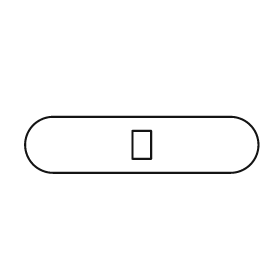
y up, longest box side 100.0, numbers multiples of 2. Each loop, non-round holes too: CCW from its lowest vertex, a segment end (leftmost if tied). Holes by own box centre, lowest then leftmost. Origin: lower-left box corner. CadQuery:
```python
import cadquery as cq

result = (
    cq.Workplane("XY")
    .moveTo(12.0, 0.0)
    .lineTo(88.0, 0.0)
    .threePointArc((100.0, 12.0), (88.0, 24.0))
    .lineTo(12.0, 24.0)
    .threePointArc((0.0, 12.0), (12.0, 0.0))
    .close()
    .moveTo(46.0, 6.0)
    .lineTo(54.0, 6.0)
    .lineTo(54.0, 18.0)
    .lineTo(46.0, 18.0)
    .close()
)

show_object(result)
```